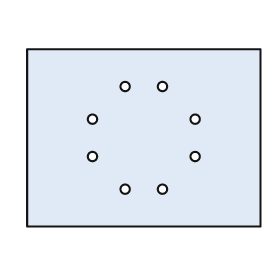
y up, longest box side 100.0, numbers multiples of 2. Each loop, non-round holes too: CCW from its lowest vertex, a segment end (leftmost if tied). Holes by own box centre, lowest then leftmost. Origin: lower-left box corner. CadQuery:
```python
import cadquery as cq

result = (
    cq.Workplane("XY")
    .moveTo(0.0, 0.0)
    .lineTo(100.0, 0.0)
    .lineTo(100.0, 76.0)
    .lineTo(0.0, 76.0)
    .close()
    .moveTo(42.0, 16.0)
    .circle(2.0)
    .moveTo(58.0, 16.0)
    .circle(2.0)
    .moveTo(28.0, 30.0)
    .circle(2.0)
    .moveTo(72.0, 30.0)
    .circle(2.0)
    .moveTo(28.0, 46.0)
    .circle(2.0)
    .moveTo(72.0, 46.0)
    .circle(2.0)
    .moveTo(42.0, 60.0)
    .circle(2.0)
    .moveTo(58.0, 60.0)
    .circle(2.0)
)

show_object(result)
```